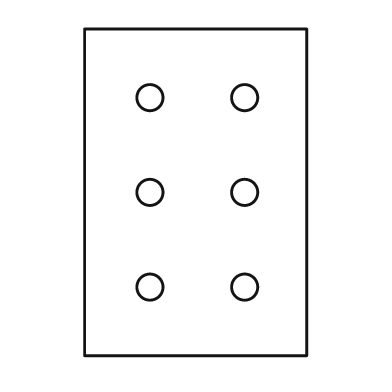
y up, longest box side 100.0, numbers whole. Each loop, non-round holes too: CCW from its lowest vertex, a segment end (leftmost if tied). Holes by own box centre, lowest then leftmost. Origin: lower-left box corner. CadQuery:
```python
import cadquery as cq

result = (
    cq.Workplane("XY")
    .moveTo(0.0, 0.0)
    .lineTo(68.0, 0.0)
    .lineTo(68.0, 100.0)
    .lineTo(0.0, 100.0)
    .close()
    .moveTo(20.0, 21.0)
    .circle(4.0)
    .moveTo(49.0, 21.0)
    .circle(4.0)
    .moveTo(20.0, 50.0)
    .circle(4.0)
    .moveTo(49.0, 50.0)
    .circle(4.0)
    .moveTo(20.0, 79.0)
    .circle(4.0)
    .moveTo(49.0, 79.0)
    .circle(4.0)
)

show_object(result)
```